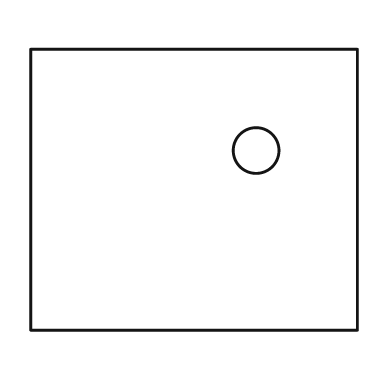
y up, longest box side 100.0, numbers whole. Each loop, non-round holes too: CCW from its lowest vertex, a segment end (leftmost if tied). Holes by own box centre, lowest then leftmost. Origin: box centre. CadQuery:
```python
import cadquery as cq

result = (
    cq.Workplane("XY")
    .moveTo(-50.0, -43.0)
    .lineTo(50.0, -43.0)
    .lineTo(50.0, 43.0)
    .lineTo(-50.0, 43.0)
    .close()
    .moveTo(19.0, 12.0)
    .circle(7.0)
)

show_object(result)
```